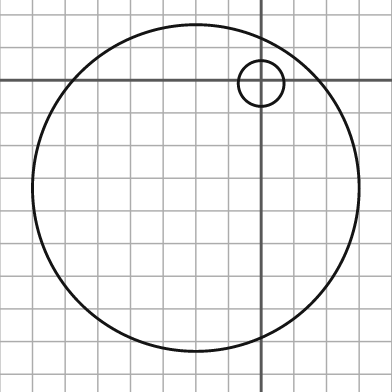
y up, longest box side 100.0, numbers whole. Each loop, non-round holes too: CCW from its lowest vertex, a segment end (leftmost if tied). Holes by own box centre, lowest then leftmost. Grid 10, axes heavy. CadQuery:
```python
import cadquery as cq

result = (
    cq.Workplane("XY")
    .moveTo(-20.0, -33.0)
    .circle(50.0)
    .moveTo(0.0, -1.0)
    .circle(7.0)
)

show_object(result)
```